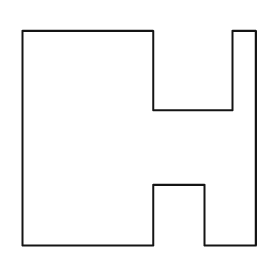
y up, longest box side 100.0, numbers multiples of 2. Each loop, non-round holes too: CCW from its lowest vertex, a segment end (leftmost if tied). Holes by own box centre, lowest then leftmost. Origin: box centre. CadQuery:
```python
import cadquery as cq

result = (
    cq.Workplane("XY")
    .moveTo(-50.0, -46.0)
    .lineTo(6.0, -46.0)
    .lineTo(6.0, -20.0)
    .lineTo(28.0, -20.0)
    .lineTo(28.0, -46.0)
    .lineTo(50.0, -46.0)
    .lineTo(50.0, 46.0)
    .lineTo(40.0, 46.0)
    .lineTo(40.0, 12.0)
    .lineTo(6.0, 12.0)
    .lineTo(6.0, 46.0)
    .lineTo(-50.0, 46.0)
    .close()
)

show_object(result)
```